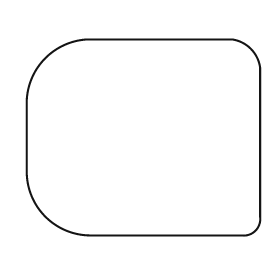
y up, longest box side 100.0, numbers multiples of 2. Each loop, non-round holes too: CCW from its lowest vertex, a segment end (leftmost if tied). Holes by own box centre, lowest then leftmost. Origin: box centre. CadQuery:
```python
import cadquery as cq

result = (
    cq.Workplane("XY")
    .moveTo(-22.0, -42.0)
    .lineTo(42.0, -42.0)
    .threePointArc((48.0, -40.0), (50.0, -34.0))
    .lineTo(50.0, 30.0)
    .threePointArc((46.0, 38.0), (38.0, 42.0))
    .lineTo(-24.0, 42.0)
    .threePointArc((-42.0, 34.0), (-50.0, 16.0))
    .lineTo(-50.0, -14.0)
    .threePointArc((-42.0, -34.0), (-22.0, -42.0))
    .close()
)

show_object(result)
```